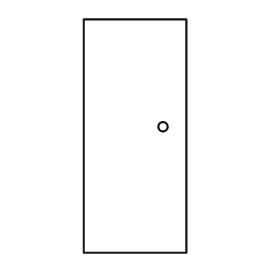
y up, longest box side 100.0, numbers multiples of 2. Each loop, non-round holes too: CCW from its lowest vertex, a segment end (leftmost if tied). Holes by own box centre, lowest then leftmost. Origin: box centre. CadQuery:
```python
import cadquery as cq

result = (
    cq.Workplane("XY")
    .moveTo(-22.0, -50.0)
    .lineTo(22.0, -50.0)
    .lineTo(22.0, 50.0)
    .lineTo(-22.0, 50.0)
    .close()
    .moveTo(12.0, 4.0)
    .circle(2.0)
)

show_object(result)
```